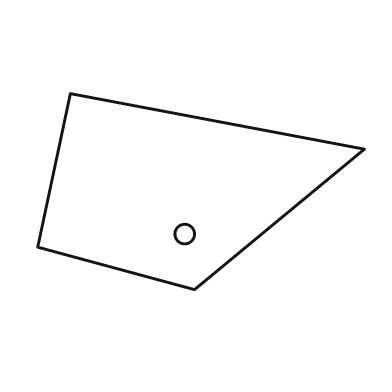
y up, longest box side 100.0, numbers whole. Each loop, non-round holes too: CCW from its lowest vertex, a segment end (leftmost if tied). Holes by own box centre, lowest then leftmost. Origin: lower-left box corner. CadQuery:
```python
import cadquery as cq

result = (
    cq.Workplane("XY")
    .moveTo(48.0, 0.0)
    .lineTo(100.0, 43.0)
    .lineTo(10.0, 60.0)
    .lineTo(0.0, 13.0)
    .close()
    .moveTo(45.0, 17.0)
    .circle(3.0)
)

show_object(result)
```